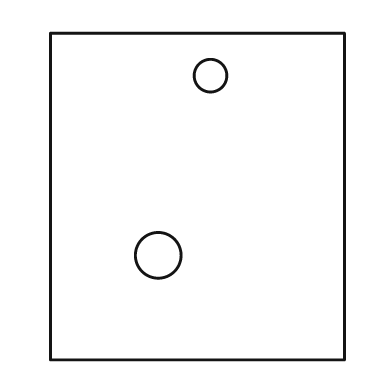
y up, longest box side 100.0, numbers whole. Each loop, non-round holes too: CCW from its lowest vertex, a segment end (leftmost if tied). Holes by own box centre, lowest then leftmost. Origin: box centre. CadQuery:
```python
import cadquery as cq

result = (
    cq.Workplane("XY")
    .moveTo(-45.0, -50.0)
    .lineTo(45.0, -50.0)
    .lineTo(45.0, 50.0)
    .lineTo(-45.0, 50.0)
    .close()
    .moveTo(-12.0, -18.0)
    .circle(7.0)
    .moveTo(4.0, 37.0)
    .circle(5.0)
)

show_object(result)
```